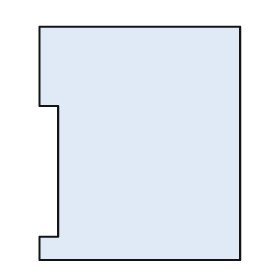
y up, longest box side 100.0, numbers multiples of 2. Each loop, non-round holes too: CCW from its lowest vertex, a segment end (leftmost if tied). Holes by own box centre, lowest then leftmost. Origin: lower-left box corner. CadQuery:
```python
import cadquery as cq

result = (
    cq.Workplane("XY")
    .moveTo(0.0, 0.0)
    .lineTo(86.0, 0.0)
    .lineTo(86.0, 100.0)
    .lineTo(0.0, 100.0)
    .lineTo(0.0, 66.0)
    .lineTo(8.0, 66.0)
    .lineTo(8.0, 10.0)
    .lineTo(0.0, 10.0)
    .close()
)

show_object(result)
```